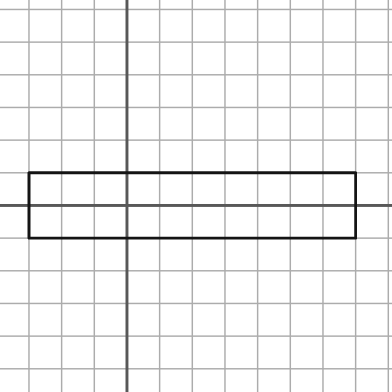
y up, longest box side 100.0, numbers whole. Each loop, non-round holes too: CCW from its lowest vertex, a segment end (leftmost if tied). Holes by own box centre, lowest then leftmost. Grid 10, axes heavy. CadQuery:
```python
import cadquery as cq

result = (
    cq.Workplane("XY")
    .moveTo(-30.0, -10.0)
    .lineTo(70.0, -10.0)
    .lineTo(70.0, 10.0)
    .lineTo(-30.0, 10.0)
    .close()
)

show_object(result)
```